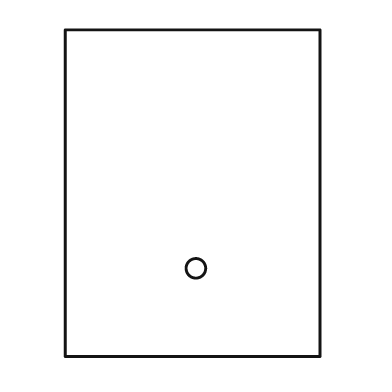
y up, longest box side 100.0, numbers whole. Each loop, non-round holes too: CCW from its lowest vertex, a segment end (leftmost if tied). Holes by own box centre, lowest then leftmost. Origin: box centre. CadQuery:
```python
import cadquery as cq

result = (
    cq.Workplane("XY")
    .moveTo(-39.0, -50.0)
    .lineTo(39.0, -50.0)
    .lineTo(39.0, 50.0)
    .lineTo(-39.0, 50.0)
    .close()
    .moveTo(1.0, -23.0)
    .circle(3.0)
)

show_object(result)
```